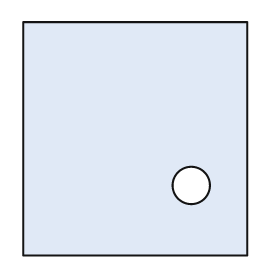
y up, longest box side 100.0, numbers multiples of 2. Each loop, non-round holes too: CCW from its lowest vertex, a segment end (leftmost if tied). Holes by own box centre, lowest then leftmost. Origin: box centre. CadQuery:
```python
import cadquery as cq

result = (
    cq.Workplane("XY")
    .moveTo(-48.0, -50.0)
    .lineTo(48.0, -50.0)
    .lineTo(48.0, 50.0)
    .lineTo(-48.0, 50.0)
    .close()
    .moveTo(24.0, -20.0)
    .circle(8.0)
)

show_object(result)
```